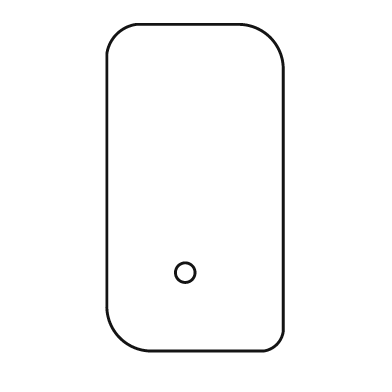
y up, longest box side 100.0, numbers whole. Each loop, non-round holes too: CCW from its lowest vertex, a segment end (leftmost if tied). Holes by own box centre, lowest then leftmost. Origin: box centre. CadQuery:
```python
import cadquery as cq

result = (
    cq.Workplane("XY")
    .moveTo(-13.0, -50.0)
    .lineTo(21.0, -50.0)
    .threePointArc((25.0, -48.0), (27.0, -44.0))
    .lineTo(27.0, 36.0)
    .threePointArc((23.0, 46.0), (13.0, 50.0))
    .lineTo(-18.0, 50.0)
    .threePointArc((-24.0, 47.0), (-27.0, 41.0))
    .lineTo(-27.0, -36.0)
    .threePointArc((-23.0, -46.0), (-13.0, -50.0))
    .close()
    .moveTo(-3.0, -26.0)
    .circle(3.0)
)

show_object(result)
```